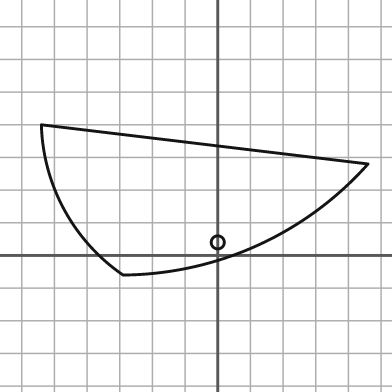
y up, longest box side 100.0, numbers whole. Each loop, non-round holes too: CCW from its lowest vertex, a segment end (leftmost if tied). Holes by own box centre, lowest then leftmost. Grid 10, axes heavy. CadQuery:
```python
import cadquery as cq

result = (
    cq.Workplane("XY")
    .moveTo(-29.0, -6.0)
    .threePointArc((12.0, 3.0), (46.0, 28.0))
    .lineTo(-54.0, 40.0)
    .threePointArc((-47.0, 14.0), (-29.0, -6.0))
    .close()
    .moveTo(0.0, 4.0)
    .circle(2.0)
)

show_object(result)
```